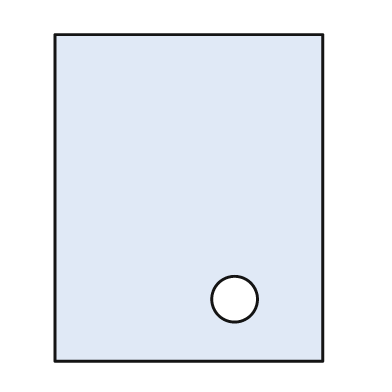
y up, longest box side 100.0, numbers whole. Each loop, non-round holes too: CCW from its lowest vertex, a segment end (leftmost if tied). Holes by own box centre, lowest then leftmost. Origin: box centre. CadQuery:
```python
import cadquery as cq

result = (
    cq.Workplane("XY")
    .moveTo(-41.0, -50.0)
    .lineTo(41.0, -50.0)
    .lineTo(41.0, 50.0)
    .lineTo(-41.0, 50.0)
    .close()
    .moveTo(14.0, -31.0)
    .circle(7.0)
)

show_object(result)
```